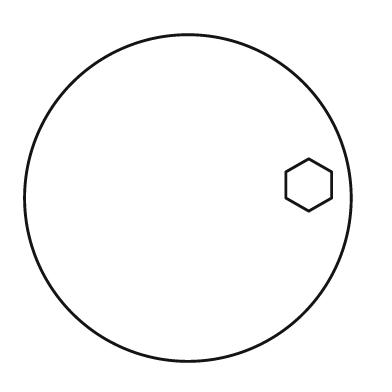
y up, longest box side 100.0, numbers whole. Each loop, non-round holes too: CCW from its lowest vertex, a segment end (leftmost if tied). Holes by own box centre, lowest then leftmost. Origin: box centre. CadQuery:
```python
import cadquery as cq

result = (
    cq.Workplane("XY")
    .moveTo(0.0, 0.0)
    .circle(50.0)
    .moveTo(37.0, -4.0)
    .lineTo(44.0, 0.0)
    .lineTo(44.0, 8.0)
    .lineTo(37.0, 12.0)
    .lineTo(30.0, 8.0)
    .lineTo(30.0, 0.0)
    .close()
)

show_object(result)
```